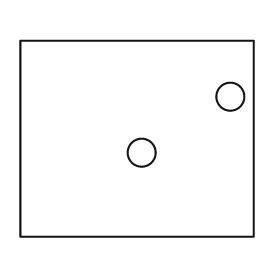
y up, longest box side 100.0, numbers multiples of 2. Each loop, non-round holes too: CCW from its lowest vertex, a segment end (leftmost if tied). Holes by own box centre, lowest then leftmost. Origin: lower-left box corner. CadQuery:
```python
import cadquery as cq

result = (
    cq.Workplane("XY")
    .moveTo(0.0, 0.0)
    .lineTo(100.0, 0.0)
    .lineTo(100.0, 84.0)
    .lineTo(0.0, 84.0)
    .close()
    .moveTo(52.0, 36.0)
    .circle(6.0)
    .moveTo(90.0, 60.0)
    .circle(6.0)
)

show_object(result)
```